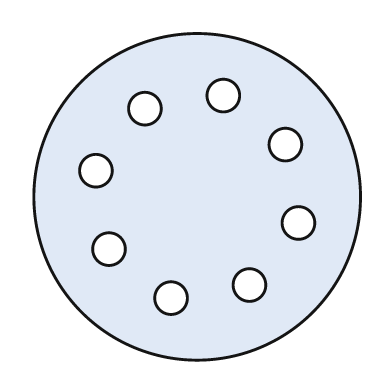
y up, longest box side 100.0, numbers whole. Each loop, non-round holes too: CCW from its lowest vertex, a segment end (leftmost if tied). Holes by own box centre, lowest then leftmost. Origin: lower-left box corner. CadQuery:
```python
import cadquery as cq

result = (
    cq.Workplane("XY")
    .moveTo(50.0, 50.0)
    .circle(50.0)
    .moveTo(42.0, 19.0)
    .circle(5.0)
    .moveTo(66.0, 23.0)
    .circle(5.0)
    .moveTo(23.0, 34.0)
    .circle(5.0)
    .moveTo(81.0, 42.0)
    .circle(5.0)
    .moveTo(19.0, 58.0)
    .circle(5.0)
    .moveTo(77.0, 66.0)
    .circle(5.0)
    .moveTo(34.0, 77.0)
    .circle(5.0)
    .moveTo(58.0, 81.0)
    .circle(5.0)
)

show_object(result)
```